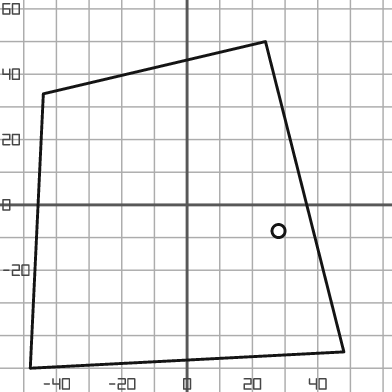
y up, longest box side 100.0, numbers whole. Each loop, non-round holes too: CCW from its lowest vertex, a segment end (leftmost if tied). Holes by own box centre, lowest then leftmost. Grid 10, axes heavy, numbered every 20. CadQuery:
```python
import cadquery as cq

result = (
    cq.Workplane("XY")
    .moveTo(-48.0, -50.0)
    .lineTo(48.0, -45.0)
    .lineTo(24.0, 50.0)
    .lineTo(-44.0, 34.0)
    .close()
    .moveTo(28.0, -8.0)
    .circle(2.0)
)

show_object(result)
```